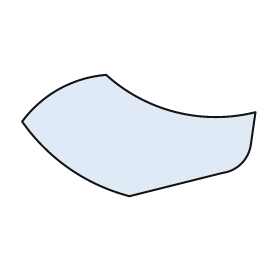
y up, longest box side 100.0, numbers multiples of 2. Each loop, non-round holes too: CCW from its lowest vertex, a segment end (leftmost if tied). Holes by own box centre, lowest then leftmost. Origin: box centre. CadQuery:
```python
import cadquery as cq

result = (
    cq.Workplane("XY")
    .moveTo(-4.0, -26.0)
    .lineTo(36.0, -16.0)
    .threePointArc((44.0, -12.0), (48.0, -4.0))
    .lineTo(50.0, 10.0)
    .threePointArc((16.0, 10.0), (-14.0, 26.0))
    .threePointArc((-34.0, 20.0), (-50.0, 6.0))
    .threePointArc((-30.0, -14.0), (-4.0, -26.0))
    .close()
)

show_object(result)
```